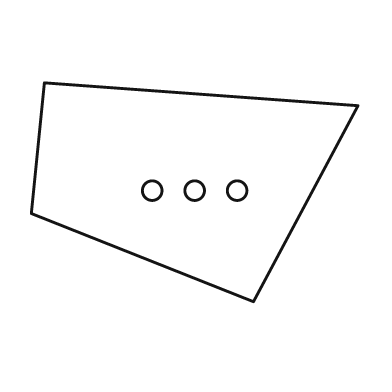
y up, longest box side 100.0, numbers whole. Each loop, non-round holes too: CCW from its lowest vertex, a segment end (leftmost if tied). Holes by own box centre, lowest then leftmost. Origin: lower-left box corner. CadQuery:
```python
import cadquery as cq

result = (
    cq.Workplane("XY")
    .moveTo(68.0, 0.0)
    .lineTo(100.0, 60.0)
    .lineTo(4.0, 67.0)
    .lineTo(0.0, 27.0)
    .close()
    .moveTo(37.0, 34.0)
    .circle(3.0)
    .moveTo(50.0, 34.0)
    .circle(3.0)
    .moveTo(63.0, 34.0)
    .circle(3.0)
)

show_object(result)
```